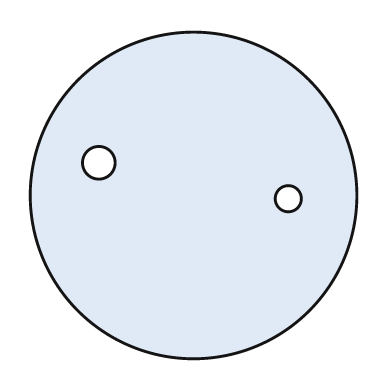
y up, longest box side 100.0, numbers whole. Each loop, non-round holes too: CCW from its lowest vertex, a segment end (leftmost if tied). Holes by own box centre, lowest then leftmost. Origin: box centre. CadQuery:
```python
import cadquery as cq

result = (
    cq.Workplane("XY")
    .moveTo(0.0, 0.0)
    .circle(50.0)
    .moveTo(29.0, -1.0)
    .circle(4.0)
    .moveTo(-29.0, 10.0)
    .circle(5.0)
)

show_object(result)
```